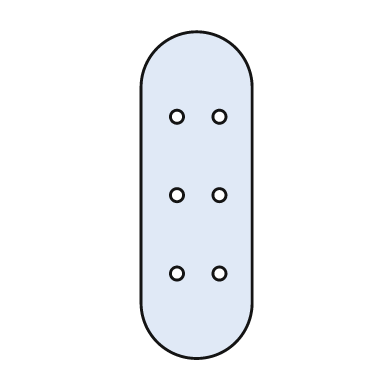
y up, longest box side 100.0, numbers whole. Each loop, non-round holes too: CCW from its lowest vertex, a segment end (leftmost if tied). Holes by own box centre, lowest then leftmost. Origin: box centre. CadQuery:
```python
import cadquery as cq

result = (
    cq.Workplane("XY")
    .moveTo(-17.0, -33.0)
    .threePointArc((0.0, -50.0), (17.0, -33.0))
    .lineTo(17.0, 33.0)
    .threePointArc((0.0, 50.0), (-17.0, 33.0))
    .close()
    .moveTo(-6.0, -24.0)
    .circle(2.0)
    .moveTo(7.0, -24.0)
    .circle(2.0)
    .moveTo(-6.0, 0.0)
    .circle(2.0)
    .moveTo(7.0, 0.0)
    .circle(2.0)
    .moveTo(-6.0, 24.0)
    .circle(2.0)
    .moveTo(7.0, 24.0)
    .circle(2.0)
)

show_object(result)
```